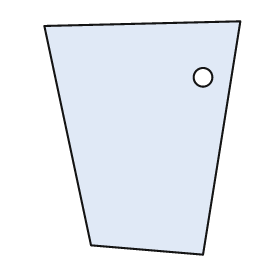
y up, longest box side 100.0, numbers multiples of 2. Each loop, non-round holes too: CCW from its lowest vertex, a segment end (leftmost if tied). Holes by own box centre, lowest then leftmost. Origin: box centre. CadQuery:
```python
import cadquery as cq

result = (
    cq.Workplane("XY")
    .moveTo(26.0, -50.0)
    .lineTo(42.0, 50.0)
    .lineTo(-42.0, 48.0)
    .lineTo(-22.0, -46.0)
    .close()
    .moveTo(26.0, 26.0)
    .circle(4.0)
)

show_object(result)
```